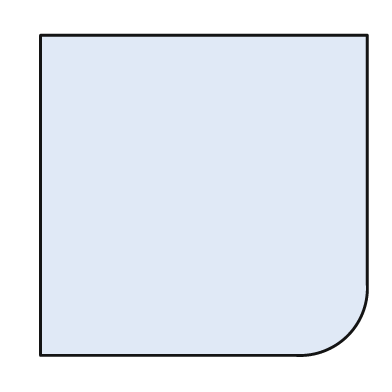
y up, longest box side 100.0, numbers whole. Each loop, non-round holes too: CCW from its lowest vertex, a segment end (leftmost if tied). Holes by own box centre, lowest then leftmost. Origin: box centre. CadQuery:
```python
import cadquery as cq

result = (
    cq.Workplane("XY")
    .moveTo(-50.0, -49.0)
    .lineTo(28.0, -49.0)
    .threePointArc((44.0, -43.0), (50.0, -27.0))
    .lineTo(50.0, 49.0)
    .lineTo(-50.0, 49.0)
    .close()
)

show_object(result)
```